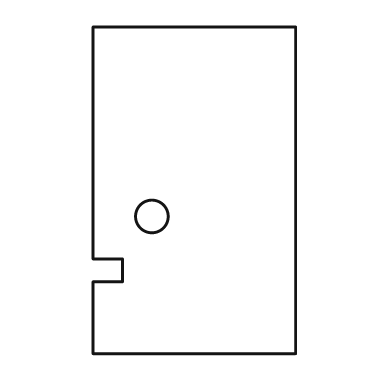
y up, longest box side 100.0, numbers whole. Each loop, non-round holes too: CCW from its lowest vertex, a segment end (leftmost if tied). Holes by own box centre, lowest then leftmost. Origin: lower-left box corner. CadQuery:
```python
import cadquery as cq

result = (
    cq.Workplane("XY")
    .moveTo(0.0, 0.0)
    .lineTo(62.0, 0.0)
    .lineTo(62.0, 100.0)
    .lineTo(0.0, 100.0)
    .lineTo(0.0, 29.0)
    .lineTo(9.0, 29.0)
    .lineTo(9.0, 22.0)
    .lineTo(0.0, 22.0)
    .close()
    .moveTo(18.0, 42.0)
    .circle(5.0)
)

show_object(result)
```